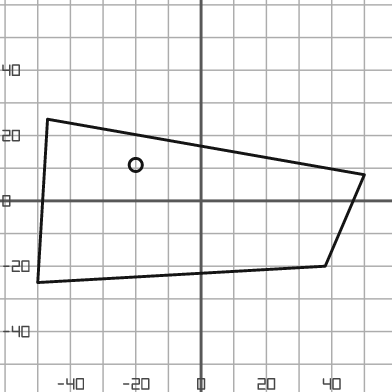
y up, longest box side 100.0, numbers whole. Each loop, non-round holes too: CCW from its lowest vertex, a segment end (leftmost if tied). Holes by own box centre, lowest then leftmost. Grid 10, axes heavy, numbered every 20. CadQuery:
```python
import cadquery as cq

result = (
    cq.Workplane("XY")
    .moveTo(-50.0, -25.0)
    .lineTo(38.0, -20.0)
    .lineTo(50.0, 8.0)
    .lineTo(-47.0, 25.0)
    .close()
    .moveTo(-20.0, 11.0)
    .circle(2.0)
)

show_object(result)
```